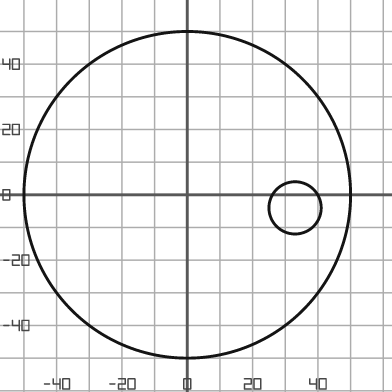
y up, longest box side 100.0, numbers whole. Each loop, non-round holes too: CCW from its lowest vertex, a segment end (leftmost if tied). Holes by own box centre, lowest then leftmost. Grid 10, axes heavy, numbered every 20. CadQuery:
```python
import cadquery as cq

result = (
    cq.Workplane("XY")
    .moveTo(0.0, 0.0)
    .circle(50.0)
    .moveTo(33.0, -4.0)
    .circle(8.0)
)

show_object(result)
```